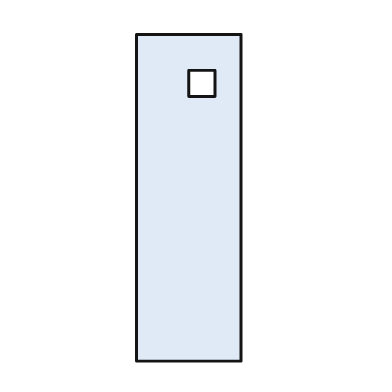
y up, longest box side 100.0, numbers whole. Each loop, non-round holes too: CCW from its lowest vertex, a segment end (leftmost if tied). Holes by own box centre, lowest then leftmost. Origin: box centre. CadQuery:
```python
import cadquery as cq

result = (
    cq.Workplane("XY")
    .moveTo(-16.0, -50.0)
    .lineTo(16.0, -50.0)
    .lineTo(16.0, 50.0)
    .lineTo(-16.0, 50.0)
    .close()
    .moveTo(0.0, 31.0)
    .lineTo(8.0, 31.0)
    .lineTo(8.0, 39.0)
    .lineTo(0.0, 39.0)
    .close()
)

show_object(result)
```